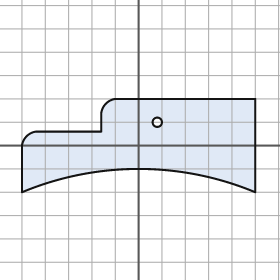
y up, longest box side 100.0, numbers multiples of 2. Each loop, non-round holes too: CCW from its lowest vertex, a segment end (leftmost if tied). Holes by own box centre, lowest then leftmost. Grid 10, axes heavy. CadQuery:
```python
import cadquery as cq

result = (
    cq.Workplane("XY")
    .moveTo(-50.0, -20.0)
    .threePointArc((0.0, -10.0), (50.0, -20.0))
    .lineTo(50.0, 20.0)
    .lineTo(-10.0, 20.0)
    .threePointArc((-14.0, 18.0), (-16.0, 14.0))
    .lineTo(-16.0, 6.0)
    .lineTo(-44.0, 6.0)
    .threePointArc((-48.0, 4.0), (-50.0, 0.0))
    .close()
    .moveTo(8.0, 10.0)
    .circle(2.0)
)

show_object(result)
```